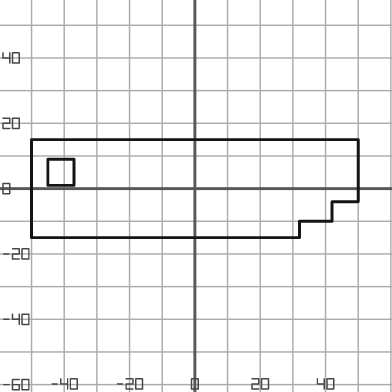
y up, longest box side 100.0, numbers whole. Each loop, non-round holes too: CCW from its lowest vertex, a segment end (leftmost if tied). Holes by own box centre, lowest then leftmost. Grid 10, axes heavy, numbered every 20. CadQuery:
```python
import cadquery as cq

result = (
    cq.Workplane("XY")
    .moveTo(-50.0, -15.0)
    .lineTo(32.0, -15.0)
    .lineTo(32.0, -10.0)
    .lineTo(42.0, -10.0)
    .lineTo(42.0, -4.0)
    .lineTo(50.0, -4.0)
    .lineTo(50.0, 15.0)
    .lineTo(-50.0, 15.0)
    .close()
    .moveTo(-45.0, 1.0)
    .lineTo(-37.0, 1.0)
    .lineTo(-37.0, 9.0)
    .lineTo(-45.0, 9.0)
    .close()
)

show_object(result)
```